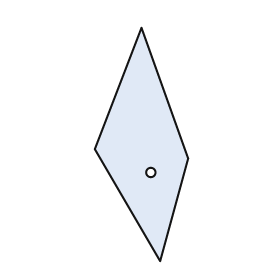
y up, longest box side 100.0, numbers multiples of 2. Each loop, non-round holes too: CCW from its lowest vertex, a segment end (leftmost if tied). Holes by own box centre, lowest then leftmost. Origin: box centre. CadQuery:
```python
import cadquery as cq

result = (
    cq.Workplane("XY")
    .moveTo(8.0, -50.0)
    .lineTo(20.0, -6.0)
    .lineTo(0.0, 50.0)
    .lineTo(-20.0, -2.0)
    .close()
    .moveTo(4.0, -12.0)
    .circle(2.0)
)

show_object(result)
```